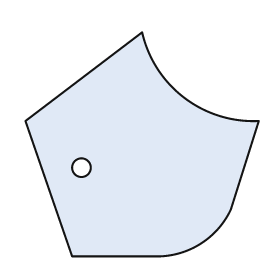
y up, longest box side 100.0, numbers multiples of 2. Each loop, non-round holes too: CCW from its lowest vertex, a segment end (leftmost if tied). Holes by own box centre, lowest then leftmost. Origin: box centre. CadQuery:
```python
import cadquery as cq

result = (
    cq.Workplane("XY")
    .moveTo(-30.0, -48.0)
    .lineTo(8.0, -48.0)
    .threePointArc((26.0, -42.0), (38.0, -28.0))
    .lineTo(50.0, 10.0)
    .threePointArc((18.0, 20.0), (0.0, 48.0))
    .lineTo(-50.0, 10.0)
    .close()
    .moveTo(-26.0, -10.0)
    .circle(4.0)
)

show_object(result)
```